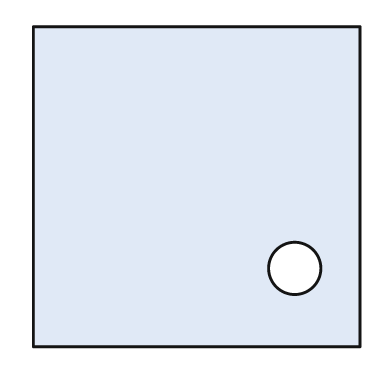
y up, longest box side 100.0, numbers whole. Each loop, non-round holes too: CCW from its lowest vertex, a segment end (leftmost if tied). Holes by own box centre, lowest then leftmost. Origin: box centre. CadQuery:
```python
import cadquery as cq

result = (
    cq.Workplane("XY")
    .moveTo(-50.0, -49.0)
    .lineTo(50.0, -49.0)
    .lineTo(50.0, 49.0)
    .lineTo(-50.0, 49.0)
    .close()
    .moveTo(30.0, -25.0)
    .circle(8.0)
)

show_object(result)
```